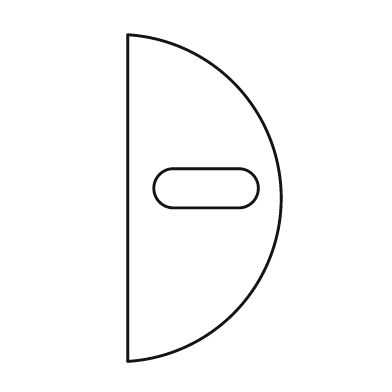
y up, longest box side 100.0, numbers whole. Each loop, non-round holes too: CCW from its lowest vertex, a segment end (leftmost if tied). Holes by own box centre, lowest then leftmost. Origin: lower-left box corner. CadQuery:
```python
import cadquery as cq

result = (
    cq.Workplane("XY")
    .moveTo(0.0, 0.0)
    .threePointArc((47.0, 50.0), (0.0, 100.0))
    .close()
    .moveTo(14.0, 47.0)
    .lineTo(34.0, 47.0)
    .threePointArc((40.0, 53.0), (34.0, 59.0))
    .lineTo(14.0, 59.0)
    .threePointArc((8.0, 53.0), (14.0, 47.0))
    .close()
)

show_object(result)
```